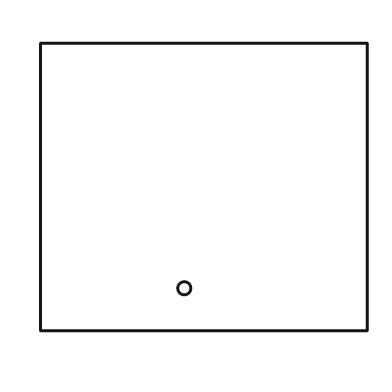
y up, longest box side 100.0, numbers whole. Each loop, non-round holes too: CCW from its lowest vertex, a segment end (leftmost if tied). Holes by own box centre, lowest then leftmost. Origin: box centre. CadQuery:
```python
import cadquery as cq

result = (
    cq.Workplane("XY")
    .moveTo(-50.0, -44.0)
    .lineTo(50.0, -44.0)
    .lineTo(50.0, 44.0)
    .lineTo(-50.0, 44.0)
    .close()
    .moveTo(-6.0, -31.0)
    .circle(2.0)
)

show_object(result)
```